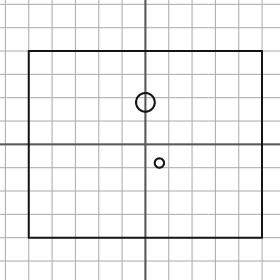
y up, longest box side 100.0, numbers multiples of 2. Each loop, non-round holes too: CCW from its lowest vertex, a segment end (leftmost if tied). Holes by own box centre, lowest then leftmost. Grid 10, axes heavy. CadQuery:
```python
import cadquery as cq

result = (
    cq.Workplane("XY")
    .moveTo(-50.0, -40.0)
    .lineTo(50.0, -40.0)
    .lineTo(50.0, 40.0)
    .lineTo(-50.0, 40.0)
    .close()
    .moveTo(6.0, -8.0)
    .circle(2.0)
    .moveTo(0.0, 18.0)
    .circle(4.0)
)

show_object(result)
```